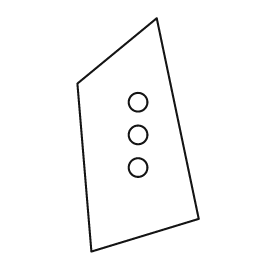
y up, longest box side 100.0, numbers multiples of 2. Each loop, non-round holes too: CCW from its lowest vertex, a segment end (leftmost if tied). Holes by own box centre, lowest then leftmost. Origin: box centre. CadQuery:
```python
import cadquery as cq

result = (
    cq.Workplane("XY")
    .moveTo(-20.0, -50.0)
    .lineTo(26.0, -36.0)
    .lineTo(8.0, 50.0)
    .lineTo(-26.0, 22.0)
    .close()
    .moveTo(0.0, -14.0)
    .circle(4.0)
    .moveTo(0.0, 0.0)
    .circle(4.0)
    .moveTo(0.0, 14.0)
    .circle(4.0)
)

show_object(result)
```